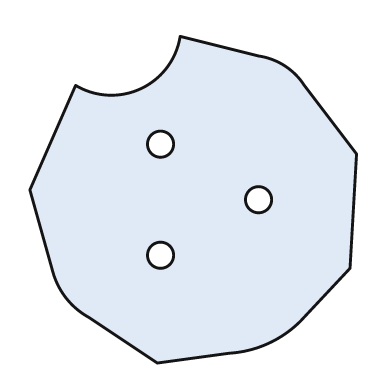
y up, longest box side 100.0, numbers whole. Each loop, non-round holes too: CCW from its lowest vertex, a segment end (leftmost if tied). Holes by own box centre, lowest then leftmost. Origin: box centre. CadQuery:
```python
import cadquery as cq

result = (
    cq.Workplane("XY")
    .moveTo(-11.0, -50.0)
    .lineTo(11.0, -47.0)
    .threePointArc((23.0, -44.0), (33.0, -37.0))
    .lineTo(48.0, -21.0)
    .lineTo(50.0, 14.0)
    .lineTo(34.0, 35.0)
    .threePointArc((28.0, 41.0), (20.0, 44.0))
    .lineTo(-4.0, 50.0)
    .threePointArc((-16.0, 34.0), (-36.0, 35.0))
    .lineTo(-50.0, 3.0)
    .lineTo(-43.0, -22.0)
    .threePointArc((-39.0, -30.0), (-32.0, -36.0))
    .close()
    .moveTo(-10.0, -17.0)
    .circle(4.0)
    .moveTo(20.0, 0.0)
    .circle(4.0)
    .moveTo(-10.0, 17.0)
    .circle(4.0)
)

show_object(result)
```